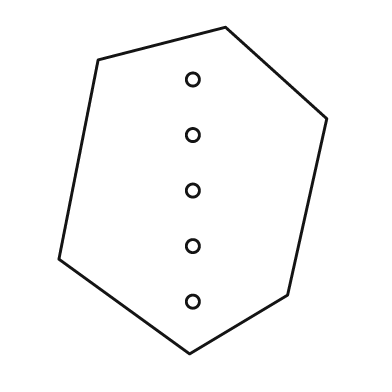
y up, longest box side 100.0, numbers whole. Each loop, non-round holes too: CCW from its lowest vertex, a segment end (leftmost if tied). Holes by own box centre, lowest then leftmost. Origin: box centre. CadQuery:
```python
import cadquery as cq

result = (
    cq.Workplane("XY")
    .moveTo(-1.0, -50.0)
    .lineTo(29.0, -32.0)
    .lineTo(41.0, 22.0)
    .lineTo(10.0, 50.0)
    .lineTo(-29.0, 40.0)
    .lineTo(-41.0, -21.0)
    .close()
    .moveTo(0.0, -34.0)
    .circle(2.0)
    .moveTo(0.0, -17.0)
    .circle(2.0)
    .moveTo(0.0, 0.0)
    .circle(2.0)
    .moveTo(0.0, 17.0)
    .circle(2.0)
    .moveTo(0.0, 34.0)
    .circle(2.0)
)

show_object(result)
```